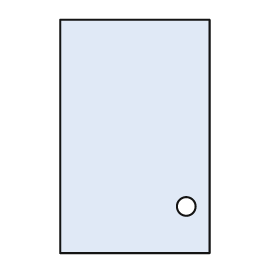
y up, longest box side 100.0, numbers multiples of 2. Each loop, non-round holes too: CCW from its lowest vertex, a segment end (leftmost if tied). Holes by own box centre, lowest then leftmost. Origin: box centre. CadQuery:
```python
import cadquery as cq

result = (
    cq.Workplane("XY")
    .moveTo(-32.0, -50.0)
    .lineTo(32.0, -50.0)
    .lineTo(32.0, 50.0)
    .lineTo(-32.0, 50.0)
    .close()
    .moveTo(22.0, -30.0)
    .circle(4.0)
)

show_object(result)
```